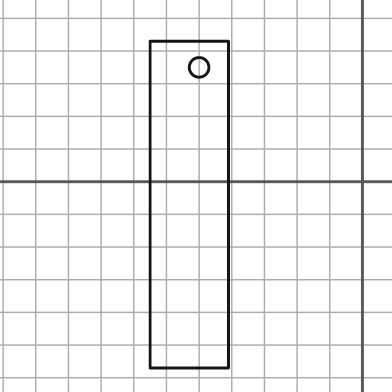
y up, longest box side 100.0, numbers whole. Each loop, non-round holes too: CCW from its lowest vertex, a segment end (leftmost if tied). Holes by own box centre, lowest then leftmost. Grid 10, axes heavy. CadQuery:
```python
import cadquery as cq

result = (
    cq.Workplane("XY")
    .moveTo(-65.0, -57.0)
    .lineTo(-41.0, -57.0)
    .lineTo(-41.0, 43.0)
    .lineTo(-65.0, 43.0)
    .close()
    .moveTo(-50.0, 35.0)
    .circle(3.0)
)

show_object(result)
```